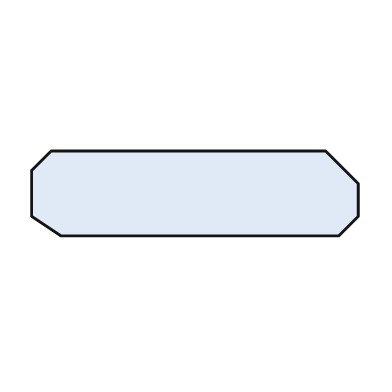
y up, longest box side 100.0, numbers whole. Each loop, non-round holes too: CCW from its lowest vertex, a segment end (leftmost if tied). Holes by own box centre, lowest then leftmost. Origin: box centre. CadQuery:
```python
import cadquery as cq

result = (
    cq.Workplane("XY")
    .moveTo(-41.0, -13.0)
    .lineTo(44.0, -13.0)
    .lineTo(50.0, -7.0)
    .lineTo(50.0, 3.0)
    .lineTo(40.0, 13.0)
    .lineTo(-44.0, 13.0)
    .lineTo(-50.0, 7.0)
    .lineTo(-50.0, -7.0)
    .close()
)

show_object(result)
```